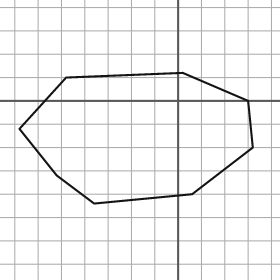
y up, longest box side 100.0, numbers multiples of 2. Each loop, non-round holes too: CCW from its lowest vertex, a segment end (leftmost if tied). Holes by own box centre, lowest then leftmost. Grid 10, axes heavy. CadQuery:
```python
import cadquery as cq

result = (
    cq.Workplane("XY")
    .moveTo(-36.0, -44.0)
    .lineTo(6.0, -40.0)
    .lineTo(32.0, -20.0)
    .lineTo(30.0, 0.0)
    .lineTo(2.0, 12.0)
    .lineTo(-48.0, 10.0)
    .lineTo(-68.0, -12.0)
    .lineTo(-52.0, -32.0)
    .close()
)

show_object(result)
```